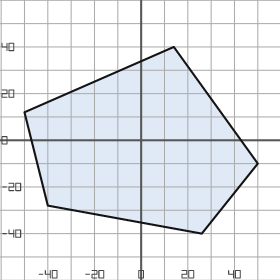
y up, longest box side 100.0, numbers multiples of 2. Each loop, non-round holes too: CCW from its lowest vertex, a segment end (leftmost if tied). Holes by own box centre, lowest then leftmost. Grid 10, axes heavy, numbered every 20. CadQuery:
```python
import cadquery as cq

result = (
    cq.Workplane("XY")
    .moveTo(26.0, -40.0)
    .lineTo(50.0, -10.0)
    .lineTo(14.0, 40.0)
    .lineTo(-50.0, 12.0)
    .lineTo(-40.0, -28.0)
    .close()
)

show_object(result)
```